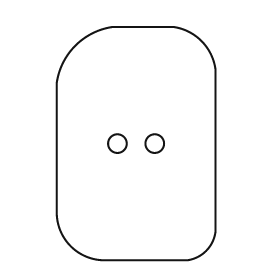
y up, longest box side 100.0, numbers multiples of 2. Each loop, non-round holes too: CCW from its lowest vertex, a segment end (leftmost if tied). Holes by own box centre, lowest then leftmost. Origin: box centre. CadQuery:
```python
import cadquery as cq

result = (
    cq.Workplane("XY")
    .moveTo(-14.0, -50.0)
    .lineTo(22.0, -50.0)
    .threePointArc((30.0, -46.0), (34.0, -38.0))
    .lineTo(34.0, 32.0)
    .threePointArc((28.0, 44.0), (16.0, 50.0))
    .lineTo(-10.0, 50.0)
    .threePointArc((-26.0, 42.0), (-34.0, 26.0))
    .lineTo(-34.0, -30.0)
    .threePointArc((-28.0, -44.0), (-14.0, -50.0))
    .close()
    .moveTo(-8.0, 0.0)
    .circle(4.0)
    .moveTo(8.0, 0.0)
    .circle(4.0)
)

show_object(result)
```